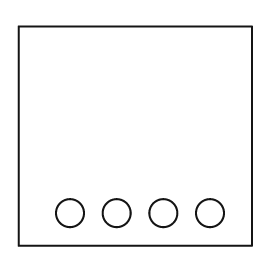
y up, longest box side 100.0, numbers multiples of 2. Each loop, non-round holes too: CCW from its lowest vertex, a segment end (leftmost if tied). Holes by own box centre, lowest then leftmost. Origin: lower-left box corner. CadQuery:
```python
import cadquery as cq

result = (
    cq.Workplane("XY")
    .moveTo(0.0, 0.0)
    .lineTo(100.0, 0.0)
    .lineTo(100.0, 94.0)
    .lineTo(0.0, 94.0)
    .close()
    .moveTo(22.0, 14.0)
    .circle(6.0)
    .moveTo(42.0, 14.0)
    .circle(6.0)
    .moveTo(62.0, 14.0)
    .circle(6.0)
    .moveTo(82.0, 14.0)
    .circle(6.0)
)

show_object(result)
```